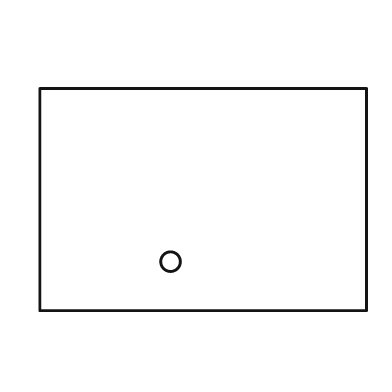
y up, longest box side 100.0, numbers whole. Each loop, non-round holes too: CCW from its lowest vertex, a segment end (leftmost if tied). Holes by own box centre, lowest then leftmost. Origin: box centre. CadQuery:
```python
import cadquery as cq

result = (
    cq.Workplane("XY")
    .moveTo(-50.0, -34.0)
    .lineTo(50.0, -34.0)
    .lineTo(50.0, 34.0)
    .lineTo(-50.0, 34.0)
    .close()
    .moveTo(-10.0, -19.0)
    .circle(3.0)
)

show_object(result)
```